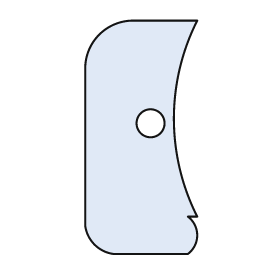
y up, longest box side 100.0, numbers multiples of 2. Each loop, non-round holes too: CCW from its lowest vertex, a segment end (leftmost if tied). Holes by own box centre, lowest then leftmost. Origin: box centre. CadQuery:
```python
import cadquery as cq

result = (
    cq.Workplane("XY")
    .moveTo(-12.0, -50.0)
    .lineTo(20.0, -50.0)
    .threePointArc((24.0, -42.0), (20.0, -34.0))
    .lineTo(24.0, -34.0)
    .threePointArc((14.0, 8.0), (24.0, 50.0))
    .lineTo(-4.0, 50.0)
    .threePointArc((-18.0, 44.0), (-24.0, 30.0))
    .lineTo(-24.0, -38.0)
    .threePointArc((-20.0, -46.0), (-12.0, -50.0))
    .close()
    .moveTo(4.0, 6.0)
    .circle(6.0)
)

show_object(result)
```